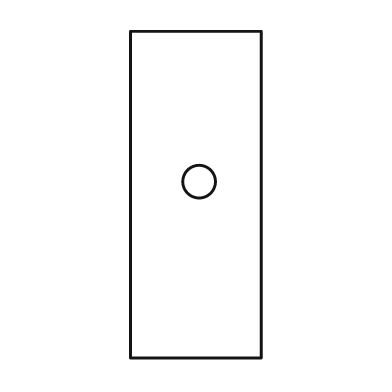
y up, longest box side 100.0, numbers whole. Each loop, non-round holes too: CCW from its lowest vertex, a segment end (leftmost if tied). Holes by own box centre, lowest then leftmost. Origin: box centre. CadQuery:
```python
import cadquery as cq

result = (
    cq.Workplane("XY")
    .moveTo(-20.0, -50.0)
    .lineTo(20.0, -50.0)
    .lineTo(20.0, 50.0)
    .lineTo(-20.0, 50.0)
    .close()
    .moveTo(1.0, 4.0)
    .circle(5.0)
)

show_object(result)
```